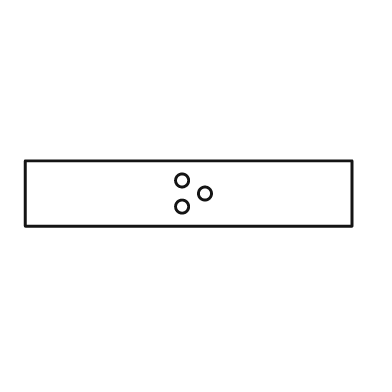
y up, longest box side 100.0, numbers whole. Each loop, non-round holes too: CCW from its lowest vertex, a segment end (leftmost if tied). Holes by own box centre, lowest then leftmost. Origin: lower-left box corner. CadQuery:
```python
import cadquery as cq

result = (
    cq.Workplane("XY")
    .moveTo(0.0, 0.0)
    .lineTo(100.0, 0.0)
    .lineTo(100.0, 20.0)
    .lineTo(0.0, 20.0)
    .close()
    .moveTo(48.0, 6.0)
    .circle(2.0)
    .moveTo(55.0, 10.0)
    .circle(2.0)
    .moveTo(48.0, 14.0)
    .circle(2.0)
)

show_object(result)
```